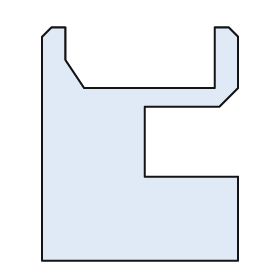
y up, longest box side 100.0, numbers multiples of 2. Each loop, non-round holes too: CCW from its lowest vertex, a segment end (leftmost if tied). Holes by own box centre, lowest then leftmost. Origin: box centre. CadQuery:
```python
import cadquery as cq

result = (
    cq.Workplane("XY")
    .moveTo(-42.0, -50.0)
    .lineTo(42.0, -50.0)
    .lineTo(42.0, -14.0)
    .lineTo(2.0, -14.0)
    .lineTo(2.0, 16.0)
    .lineTo(34.0, 16.0)
    .lineTo(42.0, 24.0)
    .lineTo(42.0, 46.0)
    .lineTo(38.0, 50.0)
    .lineTo(32.0, 50.0)
    .lineTo(32.0, 24.0)
    .lineTo(-24.0, 24.0)
    .lineTo(-32.0, 36.0)
    .lineTo(-32.0, 50.0)
    .lineTo(-38.0, 50.0)
    .lineTo(-42.0, 46.0)
    .close()
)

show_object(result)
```